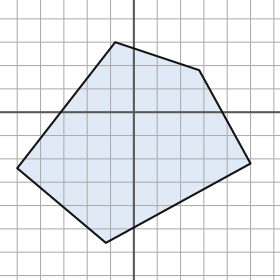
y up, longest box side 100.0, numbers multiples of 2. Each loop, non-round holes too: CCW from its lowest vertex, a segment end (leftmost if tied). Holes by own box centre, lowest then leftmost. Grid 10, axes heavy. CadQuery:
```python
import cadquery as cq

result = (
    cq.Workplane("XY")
    .moveTo(-12.0, -56.0)
    .lineTo(50.0, -22.0)
    .lineTo(28.0, 18.0)
    .lineTo(-8.0, 30.0)
    .lineTo(-50.0, -24.0)
    .close()
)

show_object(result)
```